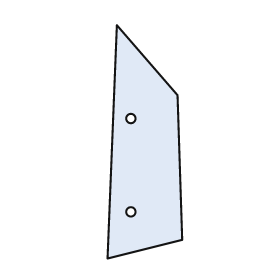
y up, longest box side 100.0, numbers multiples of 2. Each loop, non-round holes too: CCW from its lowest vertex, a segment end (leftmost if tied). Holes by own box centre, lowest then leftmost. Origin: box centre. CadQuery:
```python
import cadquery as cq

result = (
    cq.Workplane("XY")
    .moveTo(-16.0, -50.0)
    .lineTo(16.0, -42.0)
    .lineTo(14.0, 20.0)
    .lineTo(-12.0, 50.0)
    .close()
    .moveTo(-6.0, -30.0)
    .circle(2.0)
    .moveTo(-6.0, 10.0)
    .circle(2.0)
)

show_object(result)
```